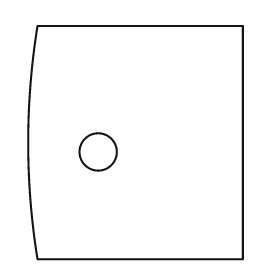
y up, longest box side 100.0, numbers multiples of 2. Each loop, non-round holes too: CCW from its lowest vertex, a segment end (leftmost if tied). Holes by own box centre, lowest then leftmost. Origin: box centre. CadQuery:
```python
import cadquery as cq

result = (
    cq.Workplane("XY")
    .moveTo(-42.0, -50.0)
    .lineTo(46.0, -50.0)
    .lineTo(46.0, 50.0)
    .lineTo(-42.0, 50.0)
    .threePointArc((-46.0, 0.0), (-42.0, -50.0))
    .close()
    .moveTo(-16.0, -4.0)
    .circle(8.0)
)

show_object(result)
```